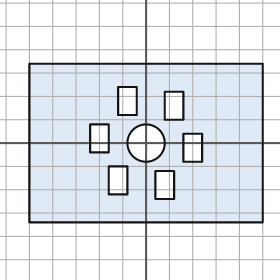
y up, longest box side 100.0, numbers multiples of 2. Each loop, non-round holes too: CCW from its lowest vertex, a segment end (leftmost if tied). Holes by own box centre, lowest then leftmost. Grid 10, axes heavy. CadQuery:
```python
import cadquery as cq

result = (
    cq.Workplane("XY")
    .moveTo(-50.0, -34.0)
    .lineTo(50.0, -34.0)
    .lineTo(50.0, 34.0)
    .lineTo(-50.0, 34.0)
    .close()
    .moveTo(4.0, -24.0)
    .lineTo(12.0, -24.0)
    .lineTo(12.0, -12.0)
    .lineTo(4.0, -12.0)
    .close()
    .moveTo(-16.0, -22.0)
    .lineTo(-8.0, -22.0)
    .lineTo(-8.0, -10.0)
    .lineTo(-16.0, -10.0)
    .close()
    .moveTo(16.0, -8.0)
    .lineTo(24.0, -8.0)
    .lineTo(24.0, 4.0)
    .lineTo(16.0, 4.0)
    .close()
    .moveTo(0.0, 0.0)
    .circle(8.0)
    .moveTo(-24.0, -4.0)
    .lineTo(-16.0, -4.0)
    .lineTo(-16.0, 8.0)
    .lineTo(-24.0, 8.0)
    .close()
    .moveTo(8.0, 10.0)
    .lineTo(16.0, 10.0)
    .lineTo(16.0, 22.0)
    .lineTo(8.0, 22.0)
    .close()
    .moveTo(-12.0, 12.0)
    .lineTo(-4.0, 12.0)
    .lineTo(-4.0, 24.0)
    .lineTo(-12.0, 24.0)
    .close()
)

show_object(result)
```